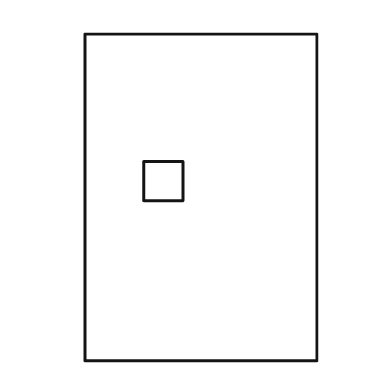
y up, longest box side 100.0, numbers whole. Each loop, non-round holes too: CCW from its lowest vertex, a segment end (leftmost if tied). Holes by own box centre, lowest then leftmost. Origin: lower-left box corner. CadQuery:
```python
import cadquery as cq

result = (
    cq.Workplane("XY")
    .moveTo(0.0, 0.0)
    .lineTo(71.0, 0.0)
    .lineTo(71.0, 100.0)
    .lineTo(0.0, 100.0)
    .close()
    .moveTo(18.0, 49.0)
    .lineTo(30.0, 49.0)
    .lineTo(30.0, 61.0)
    .lineTo(18.0, 61.0)
    .close()
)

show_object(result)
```